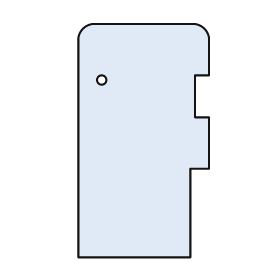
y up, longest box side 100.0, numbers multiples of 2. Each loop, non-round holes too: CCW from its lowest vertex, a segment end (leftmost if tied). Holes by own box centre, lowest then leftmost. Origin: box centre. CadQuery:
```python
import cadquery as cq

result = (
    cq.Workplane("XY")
    .moveTo(-28.0, -50.0)
    .lineTo(20.0, -50.0)
    .lineTo(20.0, -12.0)
    .lineTo(28.0, -12.0)
    .lineTo(28.0, 10.0)
    .lineTo(22.0, 10.0)
    .lineTo(22.0, 28.0)
    .lineTo(28.0, 28.0)
    .lineTo(28.0, 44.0)
    .threePointArc((26.0, 48.0), (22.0, 50.0))
    .lineTo(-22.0, 50.0)
    .threePointArc((-26.0, 48.0), (-28.0, 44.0))
    .close()
    .moveTo(-18.0, 26.0)
    .circle(2.0)
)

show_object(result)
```